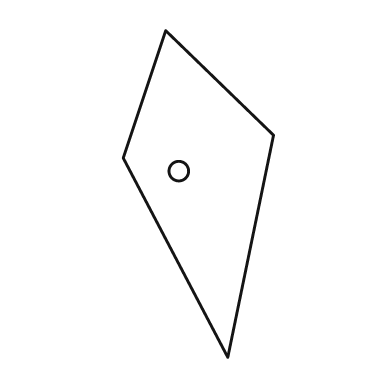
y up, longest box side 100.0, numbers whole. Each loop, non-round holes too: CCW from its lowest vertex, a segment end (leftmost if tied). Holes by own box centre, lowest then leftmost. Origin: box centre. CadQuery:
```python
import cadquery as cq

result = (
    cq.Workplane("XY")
    .moveTo(9.0, -50.0)
    .lineTo(23.0, 18.0)
    .lineTo(-10.0, 50.0)
    .lineTo(-23.0, 11.0)
    .close()
    .moveTo(-6.0, 7.0)
    .circle(3.0)
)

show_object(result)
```